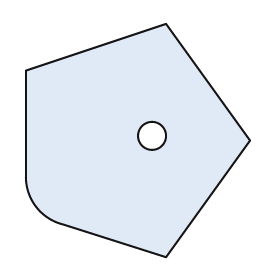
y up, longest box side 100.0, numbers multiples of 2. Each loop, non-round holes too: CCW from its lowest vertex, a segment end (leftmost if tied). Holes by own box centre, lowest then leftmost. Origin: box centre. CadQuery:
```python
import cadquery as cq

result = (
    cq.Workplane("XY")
    .moveTo(12.0, -50.0)
    .lineTo(48.0, 0.0)
    .lineTo(12.0, 50.0)
    .lineTo(-48.0, 30.0)
    .lineTo(-48.0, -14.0)
    .threePointArc((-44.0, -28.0), (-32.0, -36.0))
    .close()
    .moveTo(6.0, 2.0)
    .circle(6.0)
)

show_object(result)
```